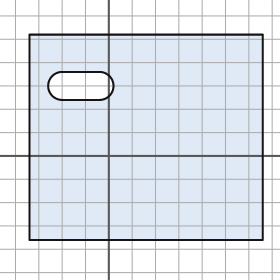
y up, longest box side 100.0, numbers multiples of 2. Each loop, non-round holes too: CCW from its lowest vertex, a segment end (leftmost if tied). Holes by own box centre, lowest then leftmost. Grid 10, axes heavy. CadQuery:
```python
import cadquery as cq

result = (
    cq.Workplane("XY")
    .moveTo(-34.0, -36.0)
    .lineTo(66.0, -36.0)
    .lineTo(66.0, 52.0)
    .lineTo(-34.0, 52.0)
    .close()
    .moveTo(-20.0, 24.0)
    .lineTo(-4.0, 24.0)
    .threePointArc((2.0, 30.0), (-4.0, 36.0))
    .lineTo(-20.0, 36.0)
    .threePointArc((-26.0, 30.0), (-20.0, 24.0))
    .close()
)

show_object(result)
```